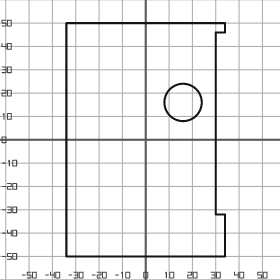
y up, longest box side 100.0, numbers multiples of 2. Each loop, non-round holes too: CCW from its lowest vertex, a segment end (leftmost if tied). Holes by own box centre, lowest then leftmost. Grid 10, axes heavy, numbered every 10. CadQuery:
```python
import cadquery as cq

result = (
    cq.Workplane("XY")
    .moveTo(-34.0, -50.0)
    .lineTo(34.0, -50.0)
    .lineTo(34.0, -32.0)
    .lineTo(30.0, -32.0)
    .lineTo(30.0, 46.0)
    .lineTo(34.0, 46.0)
    .lineTo(34.0, 50.0)
    .lineTo(-34.0, 50.0)
    .close()
    .moveTo(16.0, 16.0)
    .circle(8.0)
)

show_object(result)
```